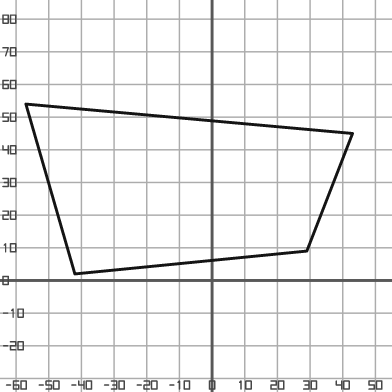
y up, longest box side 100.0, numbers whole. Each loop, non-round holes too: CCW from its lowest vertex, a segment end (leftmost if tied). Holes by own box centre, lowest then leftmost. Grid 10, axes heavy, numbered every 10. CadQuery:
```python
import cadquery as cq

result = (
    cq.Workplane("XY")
    .moveTo(-42.0, 2.0)
    .lineTo(29.0, 9.0)
    .lineTo(43.0, 45.0)
    .lineTo(-57.0, 54.0)
    .close()
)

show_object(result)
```